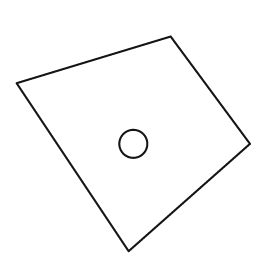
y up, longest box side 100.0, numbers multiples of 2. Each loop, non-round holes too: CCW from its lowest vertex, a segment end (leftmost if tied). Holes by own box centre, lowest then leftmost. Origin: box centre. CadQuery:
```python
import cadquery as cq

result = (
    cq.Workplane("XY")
    .moveTo(-2.0, -46.0)
    .lineTo(50.0, 0.0)
    .lineTo(16.0, 46.0)
    .lineTo(-50.0, 26.0)
    .close()
    .moveTo(0.0, 0.0)
    .circle(6.0)
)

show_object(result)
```